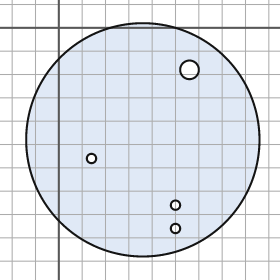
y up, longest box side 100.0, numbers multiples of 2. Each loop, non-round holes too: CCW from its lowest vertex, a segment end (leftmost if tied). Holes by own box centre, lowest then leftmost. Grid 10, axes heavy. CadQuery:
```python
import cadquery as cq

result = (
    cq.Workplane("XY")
    .moveTo(36.0, -48.0)
    .circle(50.0)
    .moveTo(50.0, -86.0)
    .circle(2.0)
    .moveTo(50.0, -76.0)
    .circle(2.0)
    .moveTo(14.0, -56.0)
    .circle(2.0)
    .moveTo(56.0, -18.0)
    .circle(4.0)
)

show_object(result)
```